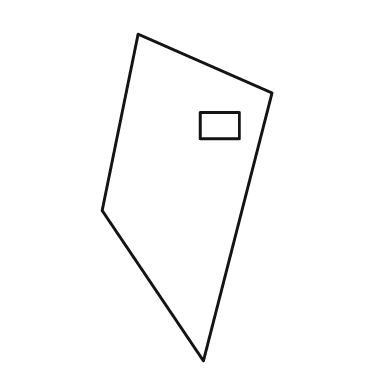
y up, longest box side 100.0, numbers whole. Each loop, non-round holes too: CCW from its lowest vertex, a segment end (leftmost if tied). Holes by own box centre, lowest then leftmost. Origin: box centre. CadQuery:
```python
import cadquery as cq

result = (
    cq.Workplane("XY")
    .moveTo(5.0, -50.0)
    .lineTo(26.0, 32.0)
    .lineTo(-15.0, 50.0)
    .lineTo(-26.0, -4.0)
    .close()
    .moveTo(4.0, 18.0)
    .lineTo(16.0, 18.0)
    .lineTo(16.0, 26.0)
    .lineTo(4.0, 26.0)
    .close()
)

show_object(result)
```